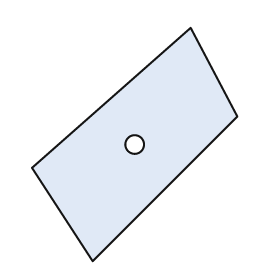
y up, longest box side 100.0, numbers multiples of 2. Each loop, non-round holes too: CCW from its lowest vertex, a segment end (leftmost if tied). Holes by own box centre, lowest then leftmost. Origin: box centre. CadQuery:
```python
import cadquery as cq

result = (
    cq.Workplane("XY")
    .moveTo(-18.0, -50.0)
    .lineTo(44.0, 12.0)
    .lineTo(24.0, 50.0)
    .lineTo(-44.0, -10.0)
    .close()
    .moveTo(0.0, 0.0)
    .circle(4.0)
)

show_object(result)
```